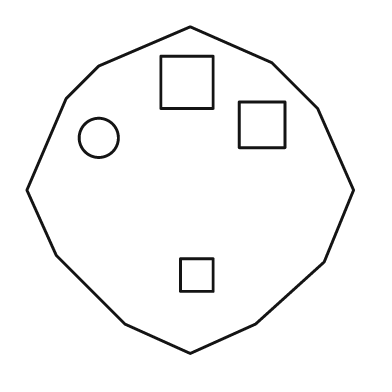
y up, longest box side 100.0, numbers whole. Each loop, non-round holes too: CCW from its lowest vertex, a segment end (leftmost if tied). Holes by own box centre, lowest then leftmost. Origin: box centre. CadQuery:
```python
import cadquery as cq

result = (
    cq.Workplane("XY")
    .moveTo(0.0, -50.0)
    .lineTo(20.0, -41.0)
    .lineTo(41.0, -22.0)
    .lineTo(50.0, 0.0)
    .lineTo(39.0, 25.0)
    .lineTo(25.0, 39.0)
    .lineTo(0.0, 50.0)
    .lineTo(-28.0, 38.0)
    .lineTo(-38.0, 28.0)
    .lineTo(-50.0, 0.0)
    .lineTo(-41.0, -20.0)
    .lineTo(-20.0, -41.0)
    .close()
    .moveTo(-3.0, -31.0)
    .lineTo(7.0, -31.0)
    .lineTo(7.0, -21.0)
    .lineTo(-3.0, -21.0)
    .close()
    .moveTo(-28.0, 16.0)
    .circle(6.0)
    .moveTo(15.0, 13.0)
    .lineTo(29.0, 13.0)
    .lineTo(29.0, 27.0)
    .lineTo(15.0, 27.0)
    .close()
    .moveTo(-9.0, 25.0)
    .lineTo(7.0, 25.0)
    .lineTo(7.0, 41.0)
    .lineTo(-9.0, 41.0)
    .close()
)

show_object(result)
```